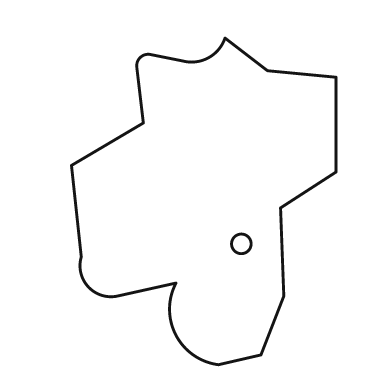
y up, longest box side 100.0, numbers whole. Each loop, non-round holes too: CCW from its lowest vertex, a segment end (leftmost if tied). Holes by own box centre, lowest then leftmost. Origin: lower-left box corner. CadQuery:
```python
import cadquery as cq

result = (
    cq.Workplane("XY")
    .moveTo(45.0, 0.0)
    .lineTo(58.0, 3.0)
    .lineTo(65.0, 21.0)
    .lineTo(64.0, 48.0)
    .lineTo(81.0, 59.0)
    .lineTo(81.0, 88.0)
    .lineTo(60.0, 90.0)
    .lineTo(47.0, 100.0)
    .threePointArc((42.0, 94.0), (34.0, 93.0))
    .lineTo(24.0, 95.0)
    .threePointArc((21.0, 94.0), (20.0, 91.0))
    .lineTo(22.0, 74.0)
    .lineTo(0.0, 61.0)
    .lineTo(3.0, 33.0)
    .threePointArc((5.0, 24.0), (14.0, 21.0))
    .lineTo(32.0, 25.0)
    .threePointArc((32.0, 9.0), (45.0, 0.0))
    .close()
    .moveTo(52.0, 37.0)
    .circle(3.0)
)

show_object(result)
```